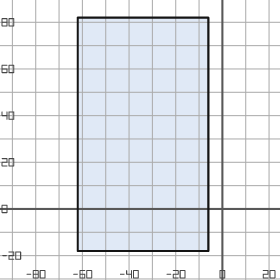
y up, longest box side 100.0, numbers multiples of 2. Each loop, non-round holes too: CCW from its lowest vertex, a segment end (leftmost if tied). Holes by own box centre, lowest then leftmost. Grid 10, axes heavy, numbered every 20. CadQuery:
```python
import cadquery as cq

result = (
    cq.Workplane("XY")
    .moveTo(-62.0, -18.0)
    .lineTo(-6.0, -18.0)
    .lineTo(-6.0, 82.0)
    .lineTo(-62.0, 82.0)
    .close()
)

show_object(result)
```